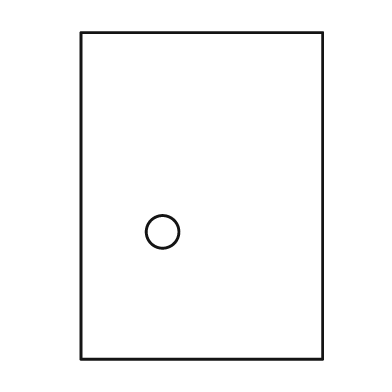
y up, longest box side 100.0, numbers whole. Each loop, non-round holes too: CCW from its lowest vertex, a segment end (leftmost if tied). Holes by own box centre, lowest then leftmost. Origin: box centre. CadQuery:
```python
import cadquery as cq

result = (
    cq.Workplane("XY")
    .moveTo(-37.0, -50.0)
    .lineTo(37.0, -50.0)
    .lineTo(37.0, 50.0)
    .lineTo(-37.0, 50.0)
    .close()
    .moveTo(-12.0, -11.0)
    .circle(5.0)
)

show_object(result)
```